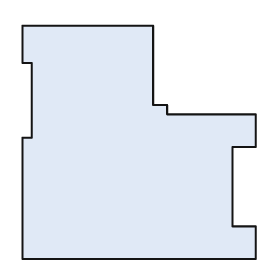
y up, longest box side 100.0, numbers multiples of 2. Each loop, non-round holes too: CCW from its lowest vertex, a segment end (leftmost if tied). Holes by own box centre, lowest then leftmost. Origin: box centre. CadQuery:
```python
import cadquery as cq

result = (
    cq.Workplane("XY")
    .moveTo(-50.0, -50.0)
    .lineTo(50.0, -50.0)
    .lineTo(50.0, -36.0)
    .lineTo(40.0, -36.0)
    .lineTo(40.0, -2.0)
    .lineTo(50.0, -2.0)
    .lineTo(50.0, 12.0)
    .lineTo(12.0, 12.0)
    .lineTo(12.0, 16.0)
    .lineTo(6.0, 16.0)
    .lineTo(6.0, 50.0)
    .lineTo(-50.0, 50.0)
    .lineTo(-50.0, 34.0)
    .lineTo(-46.0, 34.0)
    .lineTo(-46.0, 2.0)
    .lineTo(-50.0, 2.0)
    .close()
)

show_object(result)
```